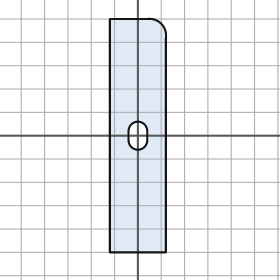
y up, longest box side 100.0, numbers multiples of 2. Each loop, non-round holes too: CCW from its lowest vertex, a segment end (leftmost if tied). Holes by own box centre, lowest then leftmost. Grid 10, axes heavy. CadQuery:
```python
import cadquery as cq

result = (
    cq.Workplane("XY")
    .moveTo(-12.0, -50.0)
    .lineTo(12.0, -50.0)
    .lineTo(12.0, 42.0)
    .threePointArc((10.0, 48.0), (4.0, 50.0))
    .lineTo(-12.0, 50.0)
    .close()
    .moveTo(-4.0, -2.0)
    .threePointArc((0.0, -6.0), (4.0, -2.0))
    .lineTo(4.0, 2.0)
    .threePointArc((0.0, 6.0), (-4.0, 2.0))
    .close()
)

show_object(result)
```